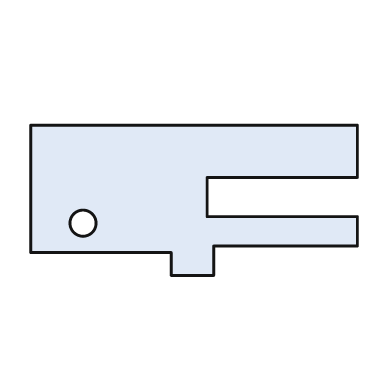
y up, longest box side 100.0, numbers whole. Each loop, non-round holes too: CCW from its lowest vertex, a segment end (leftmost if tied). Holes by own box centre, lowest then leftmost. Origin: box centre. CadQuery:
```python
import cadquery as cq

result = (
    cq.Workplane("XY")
    .moveTo(-7.0, -23.0)
    .lineTo(6.0, -23.0)
    .lineTo(6.0, -14.0)
    .lineTo(50.0, -14.0)
    .lineTo(50.0, -5.0)
    .lineTo(4.0, -5.0)
    .lineTo(4.0, 7.0)
    .lineTo(50.0, 7.0)
    .lineTo(50.0, 23.0)
    .lineTo(-50.0, 23.0)
    .lineTo(-50.0, -16.0)
    .lineTo(-7.0, -16.0)
    .close()
    .moveTo(-34.0, -7.0)
    .circle(4.0)
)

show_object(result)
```